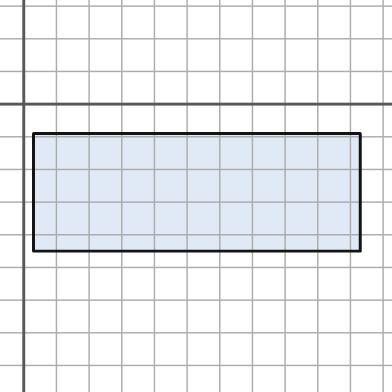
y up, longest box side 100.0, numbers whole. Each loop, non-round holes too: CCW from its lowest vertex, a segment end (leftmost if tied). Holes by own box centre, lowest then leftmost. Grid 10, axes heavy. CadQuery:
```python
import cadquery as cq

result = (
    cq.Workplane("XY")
    .moveTo(3.0, -45.0)
    .lineTo(103.0, -45.0)
    .lineTo(103.0, -9.0)
    .lineTo(3.0, -9.0)
    .close()
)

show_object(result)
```